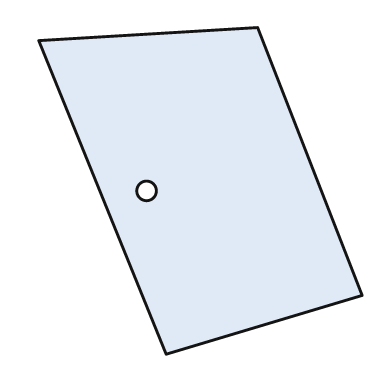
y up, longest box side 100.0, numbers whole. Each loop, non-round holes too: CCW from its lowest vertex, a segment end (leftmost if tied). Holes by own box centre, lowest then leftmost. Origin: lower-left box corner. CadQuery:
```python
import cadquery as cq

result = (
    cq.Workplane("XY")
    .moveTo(39.0, 0.0)
    .lineTo(99.0, 18.0)
    .lineTo(67.0, 100.0)
    .lineTo(0.0, 96.0)
    .close()
    .moveTo(33.0, 50.0)
    .circle(3.0)
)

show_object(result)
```